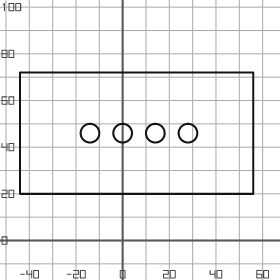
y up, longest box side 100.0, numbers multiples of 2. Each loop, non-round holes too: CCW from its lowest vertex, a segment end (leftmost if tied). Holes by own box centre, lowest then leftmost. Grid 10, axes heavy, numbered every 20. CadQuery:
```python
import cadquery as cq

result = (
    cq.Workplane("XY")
    .moveTo(-44.0, 20.0)
    .lineTo(56.0, 20.0)
    .lineTo(56.0, 72.0)
    .lineTo(-44.0, 72.0)
    .close()
    .moveTo(-14.0, 46.0)
    .circle(4.0)
    .moveTo(0.0, 46.0)
    .circle(4.0)
    .moveTo(14.0, 46.0)
    .circle(4.0)
    .moveTo(28.0, 46.0)
    .circle(4.0)
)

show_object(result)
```